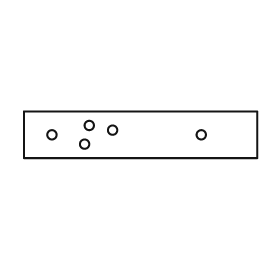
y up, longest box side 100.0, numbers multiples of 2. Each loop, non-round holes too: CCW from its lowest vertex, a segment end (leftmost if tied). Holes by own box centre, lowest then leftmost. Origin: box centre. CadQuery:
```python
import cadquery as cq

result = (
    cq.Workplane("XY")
    .moveTo(-50.0, -10.0)
    .lineTo(50.0, -10.0)
    .lineTo(50.0, 10.0)
    .lineTo(-50.0, 10.0)
    .close()
    .moveTo(-24.0, -4.0)
    .circle(2.0)
    .moveTo(-38.0, 0.0)
    .circle(2.0)
    .moveTo(26.0, 0.0)
    .circle(2.0)
    .moveTo(-12.0, 2.0)
    .circle(2.0)
    .moveTo(-22.0, 4.0)
    .circle(2.0)
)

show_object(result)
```